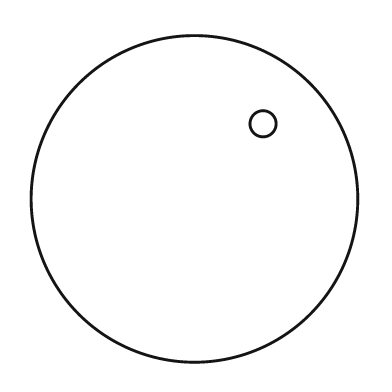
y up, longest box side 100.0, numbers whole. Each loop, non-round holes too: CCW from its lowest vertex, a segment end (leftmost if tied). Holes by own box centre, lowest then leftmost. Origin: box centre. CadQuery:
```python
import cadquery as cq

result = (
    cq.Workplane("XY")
    .moveTo(0.0, 0.0)
    .circle(50.0)
    .moveTo(21.0, 23.0)
    .circle(4.0)
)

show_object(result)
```